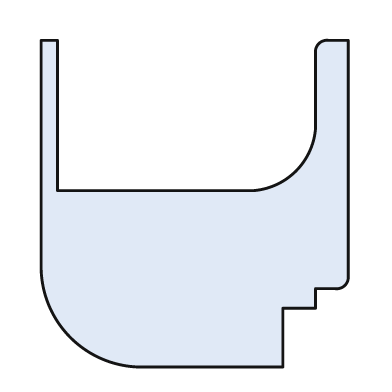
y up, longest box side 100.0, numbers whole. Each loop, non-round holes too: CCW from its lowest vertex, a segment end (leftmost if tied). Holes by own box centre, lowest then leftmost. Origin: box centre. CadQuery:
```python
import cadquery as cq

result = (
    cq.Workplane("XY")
    .moveTo(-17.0, -50.0)
    .lineTo(27.0, -50.0)
    .lineTo(27.0, -32.0)
    .lineTo(37.0, -32.0)
    .lineTo(37.0, -26.0)
    .lineTo(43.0, -26.0)
    .threePointArc((46.0, -25.0), (47.0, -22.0))
    .lineTo(47.0, 50.0)
    .lineTo(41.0, 50.0)
    .threePointArc((38.0, 49.0), (37.0, 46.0))
    .lineTo(37.0, 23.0)
    .threePointArc((31.0, 10.0), (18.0, 4.0))
    .lineTo(-42.0, 4.0)
    .lineTo(-42.0, 50.0)
    .lineTo(-47.0, 50.0)
    .lineTo(-47.0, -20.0)
    .threePointArc((-38.0, -41.0), (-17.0, -50.0))
    .close()
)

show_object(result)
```